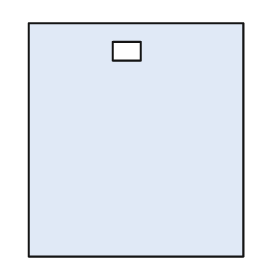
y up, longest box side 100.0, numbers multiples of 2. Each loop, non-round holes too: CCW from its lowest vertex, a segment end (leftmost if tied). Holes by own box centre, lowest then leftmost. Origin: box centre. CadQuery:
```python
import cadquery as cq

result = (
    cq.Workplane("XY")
    .moveTo(-46.0, -50.0)
    .lineTo(46.0, -50.0)
    .lineTo(46.0, 50.0)
    .lineTo(-46.0, 50.0)
    .close()
    .moveTo(-10.0, 34.0)
    .lineTo(2.0, 34.0)
    .lineTo(2.0, 42.0)
    .lineTo(-10.0, 42.0)
    .close()
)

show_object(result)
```